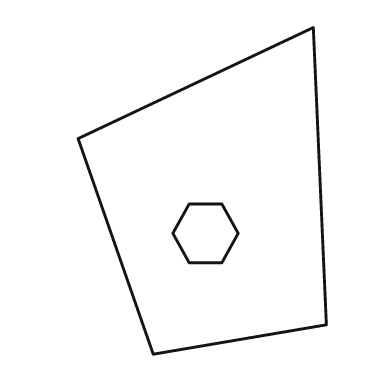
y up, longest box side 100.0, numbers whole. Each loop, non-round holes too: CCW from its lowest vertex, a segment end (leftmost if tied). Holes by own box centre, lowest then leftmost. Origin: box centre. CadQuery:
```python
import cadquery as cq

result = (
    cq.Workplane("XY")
    .moveTo(-15.0, -50.0)
    .lineTo(38.0, -41.0)
    .lineTo(34.0, 50.0)
    .lineTo(-38.0, 16.0)
    .close()
    .moveTo(-4.0, -22.0)
    .lineTo(6.0, -22.0)
    .lineTo(11.0, -13.0)
    .lineTo(6.0, -4.0)
    .lineTo(-4.0, -4.0)
    .lineTo(-9.0, -13.0)
    .close()
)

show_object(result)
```